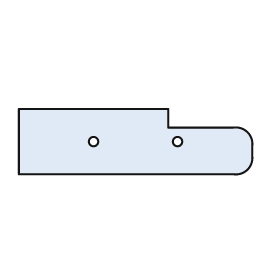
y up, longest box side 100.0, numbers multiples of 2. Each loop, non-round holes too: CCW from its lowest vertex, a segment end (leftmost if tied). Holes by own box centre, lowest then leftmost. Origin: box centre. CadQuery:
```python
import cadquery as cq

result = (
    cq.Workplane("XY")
    .moveTo(-50.0, -14.0)
    .lineTo(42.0, -14.0)
    .threePointArc((48.0, -12.0), (50.0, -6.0))
    .lineTo(50.0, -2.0)
    .threePointArc((48.0, 4.0), (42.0, 6.0))
    .lineTo(14.0, 6.0)
    .lineTo(14.0, 14.0)
    .lineTo(-50.0, 14.0)
    .close()
    .moveTo(-18.0, 0.0)
    .circle(2.0)
    .moveTo(18.0, 0.0)
    .circle(2.0)
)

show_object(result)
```